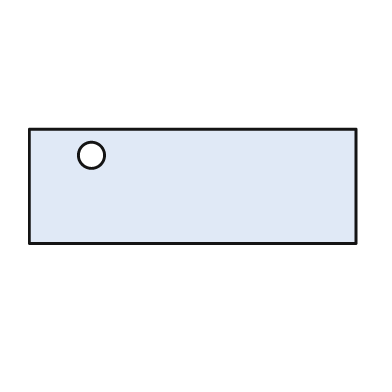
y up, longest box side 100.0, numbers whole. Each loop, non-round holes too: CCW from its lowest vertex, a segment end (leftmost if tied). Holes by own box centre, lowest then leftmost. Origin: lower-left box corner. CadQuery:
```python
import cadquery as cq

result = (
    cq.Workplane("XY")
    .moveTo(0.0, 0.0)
    .lineTo(100.0, 0.0)
    .lineTo(100.0, 35.0)
    .lineTo(0.0, 35.0)
    .close()
    .moveTo(19.0, 27.0)
    .circle(4.0)
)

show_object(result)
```